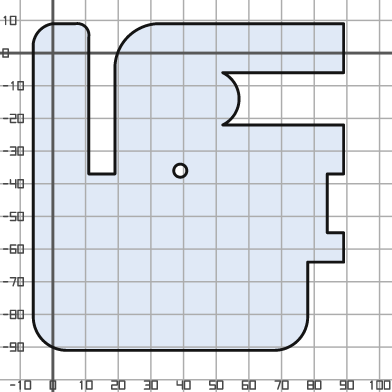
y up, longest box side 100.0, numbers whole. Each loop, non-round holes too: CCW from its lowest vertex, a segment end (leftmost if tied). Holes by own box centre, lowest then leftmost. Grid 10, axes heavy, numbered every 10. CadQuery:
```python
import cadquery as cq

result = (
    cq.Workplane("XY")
    .moveTo(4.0, -91.0)
    .lineTo(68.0, -91.0)
    .threePointArc((75.0, -88.0), (78.0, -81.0))
    .lineTo(78.0, -64.0)
    .lineTo(89.0, -64.0)
    .lineTo(89.0, -55.0)
    .lineTo(84.0, -55.0)
    .lineTo(84.0, -37.0)
    .lineTo(89.0, -37.0)
    .lineTo(89.0, -22.0)
    .lineTo(52.0, -22.0)
    .threePointArc((57.0, -14.0), (52.0, -6.0))
    .lineTo(89.0, -6.0)
    .lineTo(89.0, 9.0)
    .lineTo(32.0, 9.0)
    .threePointArc((23.0, 5.0), (19.0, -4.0))
    .lineTo(19.0, -37.0)
    .lineTo(11.0, -37.0)
    .lineTo(11.0, 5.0)
    .threePointArc((10.0, 8.0), (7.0, 9.0))
    .lineTo(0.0, 9.0)
    .threePointArc((-4.0, 7.0), (-6.0, 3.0))
    .lineTo(-6.0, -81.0)
    .threePointArc((-3.0, -88.0), (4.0, -91.0))
    .close()
    .moveTo(39.0, -36.0)
    .circle(2.0)
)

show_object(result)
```